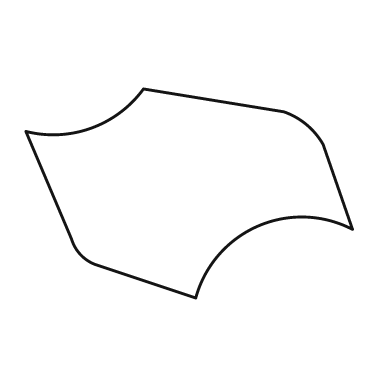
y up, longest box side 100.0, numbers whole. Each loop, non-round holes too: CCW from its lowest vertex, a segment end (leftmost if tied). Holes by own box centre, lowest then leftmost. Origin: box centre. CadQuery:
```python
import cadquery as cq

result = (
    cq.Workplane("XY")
    .moveTo(2.0, -32.0)
    .threePointArc((21.0, -10.0), (50.0, -11.0))
    .lineTo(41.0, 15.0)
    .threePointArc((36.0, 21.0), (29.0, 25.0))
    .lineTo(-14.0, 32.0)
    .threePointArc((-30.0, 20.0), (-50.0, 19.0))
    .lineTo(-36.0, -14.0)
    .threePointArc((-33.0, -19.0), (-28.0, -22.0))
    .close()
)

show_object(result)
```